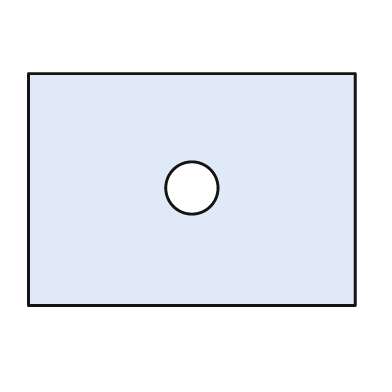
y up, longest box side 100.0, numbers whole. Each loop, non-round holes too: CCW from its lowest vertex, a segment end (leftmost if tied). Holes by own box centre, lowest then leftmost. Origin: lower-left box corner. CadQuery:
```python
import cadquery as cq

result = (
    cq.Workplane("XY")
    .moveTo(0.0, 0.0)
    .lineTo(100.0, 0.0)
    .lineTo(100.0, 71.0)
    .lineTo(0.0, 71.0)
    .close()
    .moveTo(50.0, 36.0)
    .circle(8.0)
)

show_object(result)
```